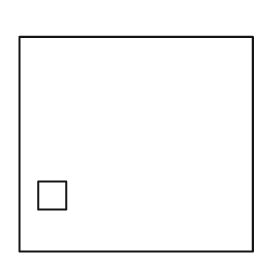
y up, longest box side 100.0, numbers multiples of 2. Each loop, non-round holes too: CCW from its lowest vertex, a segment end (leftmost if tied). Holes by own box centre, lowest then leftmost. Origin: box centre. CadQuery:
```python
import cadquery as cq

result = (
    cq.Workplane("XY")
    .moveTo(-50.0, -46.0)
    .lineTo(50.0, -46.0)
    .lineTo(50.0, 46.0)
    .lineTo(-50.0, 46.0)
    .close()
    .moveTo(-42.0, -28.0)
    .lineTo(-30.0, -28.0)
    .lineTo(-30.0, -16.0)
    .lineTo(-42.0, -16.0)
    .close()
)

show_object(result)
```